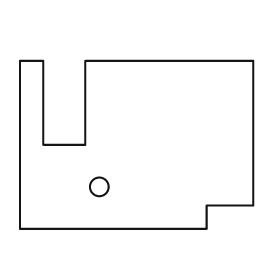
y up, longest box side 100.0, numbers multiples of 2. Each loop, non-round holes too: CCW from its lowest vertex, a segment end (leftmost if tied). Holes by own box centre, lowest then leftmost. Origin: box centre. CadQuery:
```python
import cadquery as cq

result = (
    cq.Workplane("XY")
    .moveTo(-50.0, -36.0)
    .lineTo(30.0, -36.0)
    .lineTo(30.0, -26.0)
    .lineTo(50.0, -26.0)
    .lineTo(50.0, 36.0)
    .lineTo(-22.0, 36.0)
    .lineTo(-22.0, 0.0)
    .lineTo(-40.0, 0.0)
    .lineTo(-40.0, 36.0)
    .lineTo(-50.0, 36.0)
    .close()
    .moveTo(-16.0, -18.0)
    .circle(4.0)
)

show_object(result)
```